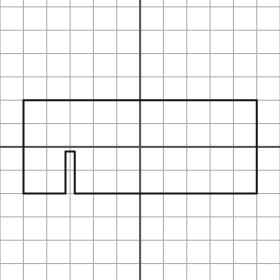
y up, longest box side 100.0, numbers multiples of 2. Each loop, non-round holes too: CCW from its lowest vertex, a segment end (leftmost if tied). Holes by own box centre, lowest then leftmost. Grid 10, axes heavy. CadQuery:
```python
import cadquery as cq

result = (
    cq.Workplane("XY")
    .moveTo(-50.0, -20.0)
    .lineTo(-32.0, -20.0)
    .lineTo(-32.0, -2.0)
    .lineTo(-28.0, -2.0)
    .lineTo(-28.0, -20.0)
    .lineTo(50.0, -20.0)
    .lineTo(50.0, 20.0)
    .lineTo(-50.0, 20.0)
    .close()
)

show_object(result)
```